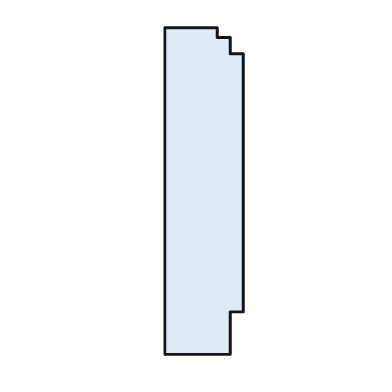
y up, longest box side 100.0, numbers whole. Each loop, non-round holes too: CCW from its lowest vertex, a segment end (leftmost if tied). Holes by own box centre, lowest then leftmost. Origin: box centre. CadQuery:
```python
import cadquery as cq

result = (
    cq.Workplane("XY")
    .moveTo(-12.0, -50.0)
    .lineTo(8.0, -50.0)
    .lineTo(8.0, -37.0)
    .lineTo(12.0, -37.0)
    .lineTo(12.0, 42.0)
    .lineTo(8.0, 42.0)
    .lineTo(8.0, 47.0)
    .lineTo(4.0, 47.0)
    .lineTo(4.0, 50.0)
    .lineTo(-12.0, 50.0)
    .close()
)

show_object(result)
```